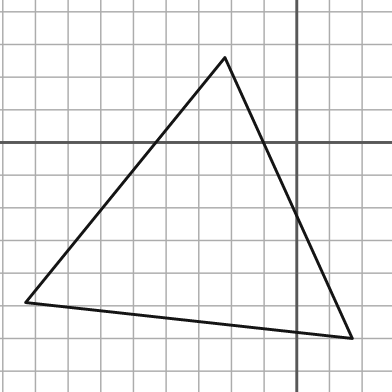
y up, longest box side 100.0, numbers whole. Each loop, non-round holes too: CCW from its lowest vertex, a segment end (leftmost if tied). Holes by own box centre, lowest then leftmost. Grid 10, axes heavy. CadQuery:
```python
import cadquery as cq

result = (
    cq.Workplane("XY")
    .moveTo(17.0, -60.0)
    .lineTo(-22.0, 26.0)
    .lineTo(-83.0, -49.0)
    .close()
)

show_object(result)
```